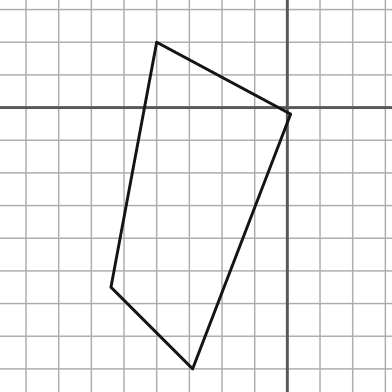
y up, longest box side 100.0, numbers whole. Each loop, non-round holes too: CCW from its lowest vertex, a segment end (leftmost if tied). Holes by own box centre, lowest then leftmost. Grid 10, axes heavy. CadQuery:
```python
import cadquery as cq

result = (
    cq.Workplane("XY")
    .moveTo(-29.0, -80.0)
    .lineTo(1.0, -2.0)
    .lineTo(-40.0, 20.0)
    .lineTo(-54.0, -55.0)
    .close()
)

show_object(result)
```